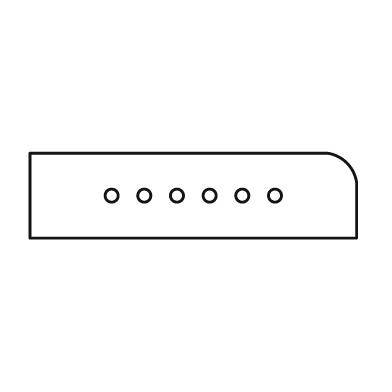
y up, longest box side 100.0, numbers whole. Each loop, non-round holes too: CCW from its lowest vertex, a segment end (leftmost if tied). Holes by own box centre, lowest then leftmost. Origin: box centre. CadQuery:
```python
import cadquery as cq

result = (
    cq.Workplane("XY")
    .moveTo(-50.0, -13.0)
    .lineTo(50.0, -13.0)
    .lineTo(50.0, 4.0)
    .threePointArc((47.0, 10.0), (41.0, 13.0))
    .lineTo(-50.0, 13.0)
    .close()
    .moveTo(-25.0, 0.0)
    .circle(2.0)
    .moveTo(-15.0, 0.0)
    .circle(2.0)
    .moveTo(-5.0, 0.0)
    .circle(2.0)
    .moveTo(5.0, 0.0)
    .circle(2.0)
    .moveTo(15.0, 0.0)
    .circle(2.0)
    .moveTo(25.0, 0.0)
    .circle(2.0)
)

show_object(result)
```